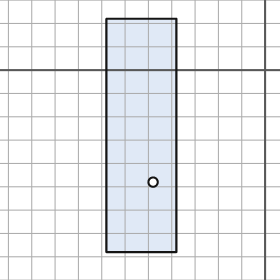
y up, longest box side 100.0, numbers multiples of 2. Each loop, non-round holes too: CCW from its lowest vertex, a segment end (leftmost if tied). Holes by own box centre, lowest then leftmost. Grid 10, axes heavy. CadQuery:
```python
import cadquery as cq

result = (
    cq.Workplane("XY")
    .moveTo(-68.0, -78.0)
    .lineTo(-38.0, -78.0)
    .lineTo(-38.0, 22.0)
    .lineTo(-68.0, 22.0)
    .close()
    .moveTo(-48.0, -48.0)
    .circle(2.0)
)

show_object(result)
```